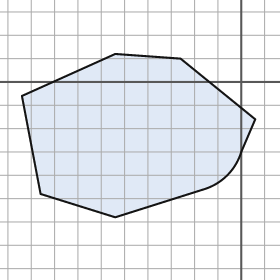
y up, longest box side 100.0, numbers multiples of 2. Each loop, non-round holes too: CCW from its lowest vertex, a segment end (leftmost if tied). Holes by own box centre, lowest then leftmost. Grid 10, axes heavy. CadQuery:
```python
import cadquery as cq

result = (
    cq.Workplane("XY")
    .moveTo(-54.0, -58.0)
    .lineTo(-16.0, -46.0)
    .threePointArc((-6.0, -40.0), (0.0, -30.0))
    .lineTo(6.0, -16.0)
    .lineTo(-26.0, 10.0)
    .lineTo(-54.0, 12.0)
    .lineTo(-94.0, -6.0)
    .lineTo(-86.0, -48.0)
    .close()
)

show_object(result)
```